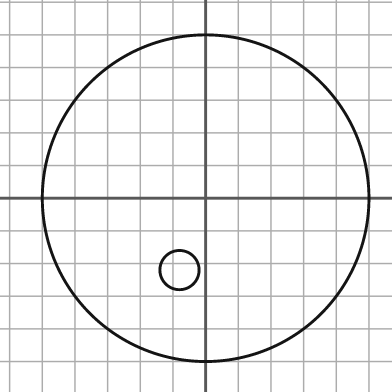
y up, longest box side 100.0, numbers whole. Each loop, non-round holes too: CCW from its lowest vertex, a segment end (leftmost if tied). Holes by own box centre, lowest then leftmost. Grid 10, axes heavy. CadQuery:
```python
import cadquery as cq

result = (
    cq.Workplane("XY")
    .moveTo(0.0, 0.0)
    .circle(50.0)
    .moveTo(-8.0, -22.0)
    .circle(6.0)
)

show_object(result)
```